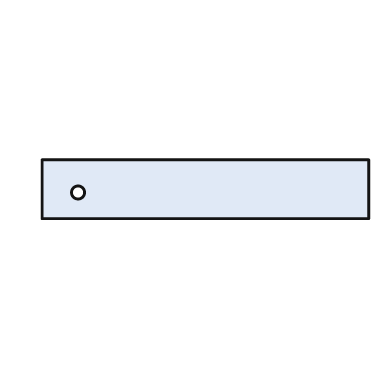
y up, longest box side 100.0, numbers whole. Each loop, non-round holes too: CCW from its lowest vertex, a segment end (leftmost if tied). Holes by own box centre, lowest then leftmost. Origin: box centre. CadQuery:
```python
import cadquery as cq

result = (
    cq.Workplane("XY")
    .moveTo(-50.0, -9.0)
    .lineTo(50.0, -9.0)
    .lineTo(50.0, 9.0)
    .lineTo(-50.0, 9.0)
    .close()
    .moveTo(-39.0, -1.0)
    .circle(2.0)
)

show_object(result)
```